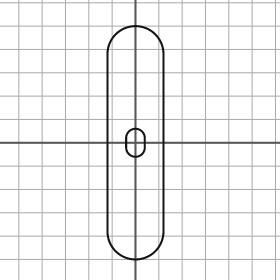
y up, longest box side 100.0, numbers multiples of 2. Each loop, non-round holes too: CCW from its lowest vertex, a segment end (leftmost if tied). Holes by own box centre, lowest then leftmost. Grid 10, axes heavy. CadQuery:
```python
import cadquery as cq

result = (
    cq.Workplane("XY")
    .moveTo(-12.0, -38.0)
    .threePointArc((0.0, -50.0), (12.0, -38.0))
    .lineTo(12.0, 38.0)
    .threePointArc((0.0, 50.0), (-12.0, 38.0))
    .close()
    .moveTo(-4.0, -2.0)
    .threePointArc((0.0, -6.0), (4.0, -2.0))
    .lineTo(4.0, 2.0)
    .threePointArc((0.0, 6.0), (-4.0, 2.0))
    .close()
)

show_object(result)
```